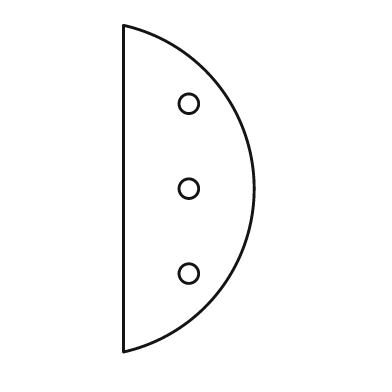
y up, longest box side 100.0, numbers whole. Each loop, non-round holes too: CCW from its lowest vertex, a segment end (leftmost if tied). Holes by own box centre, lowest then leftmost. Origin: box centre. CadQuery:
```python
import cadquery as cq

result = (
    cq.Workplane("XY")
    .moveTo(-20.0, -50.0)
    .threePointArc((20.0, 0.0), (-20.0, 50.0))
    .close()
    .moveTo(0.0, -26.0)
    .circle(3.0)
    .moveTo(0.0, 0.0)
    .circle(3.0)
    .moveTo(0.0, 26.0)
    .circle(3.0)
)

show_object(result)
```